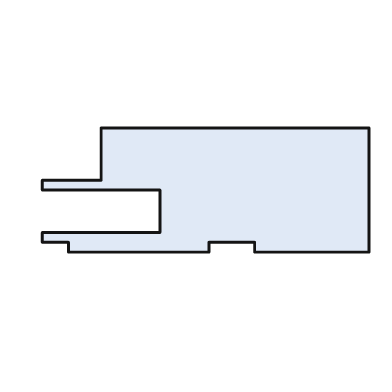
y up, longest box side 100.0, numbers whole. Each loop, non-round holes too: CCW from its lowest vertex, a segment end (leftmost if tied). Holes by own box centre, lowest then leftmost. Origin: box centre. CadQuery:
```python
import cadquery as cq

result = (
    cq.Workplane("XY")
    .moveTo(-42.0, -19.0)
    .lineTo(1.0, -19.0)
    .lineTo(1.0, -16.0)
    .lineTo(15.0, -16.0)
    .lineTo(15.0, -19.0)
    .lineTo(50.0, -19.0)
    .lineTo(50.0, 19.0)
    .lineTo(-32.0, 19.0)
    .lineTo(-32.0, 3.0)
    .lineTo(-50.0, 3.0)
    .lineTo(-50.0, 0.0)
    .lineTo(-14.0, 0.0)
    .lineTo(-14.0, -13.0)
    .lineTo(-50.0, -13.0)
    .lineTo(-50.0, -16.0)
    .lineTo(-42.0, -16.0)
    .close()
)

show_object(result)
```